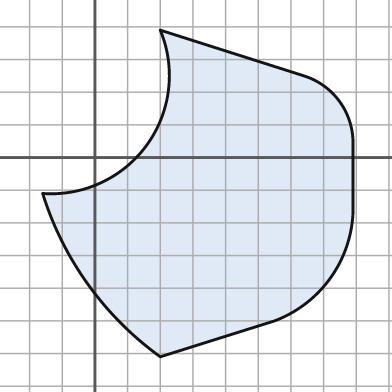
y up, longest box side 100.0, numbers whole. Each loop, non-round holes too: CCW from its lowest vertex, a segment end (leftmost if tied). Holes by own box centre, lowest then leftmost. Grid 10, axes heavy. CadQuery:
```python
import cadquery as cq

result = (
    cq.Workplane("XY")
    .moveTo(20.0, -61.0)
    .lineTo(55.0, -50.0)
    .threePointArc((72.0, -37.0), (79.0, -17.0))
    .lineTo(79.0, 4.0)
    .threePointArc((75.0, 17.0), (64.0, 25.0))
    .lineTo(20.0, 39.0)
    .threePointArc((16.0, 4.0), (-16.0, -11.0))
    .threePointArc((-2.0, -39.0), (20.0, -61.0))
    .close()
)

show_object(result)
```